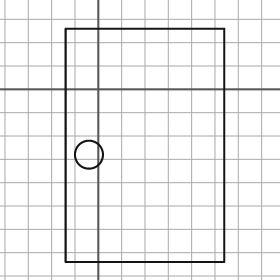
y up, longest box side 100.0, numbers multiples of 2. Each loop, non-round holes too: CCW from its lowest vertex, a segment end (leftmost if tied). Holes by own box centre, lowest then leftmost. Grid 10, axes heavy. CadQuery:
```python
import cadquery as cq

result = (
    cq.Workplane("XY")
    .moveTo(-14.0, -74.0)
    .lineTo(54.0, -74.0)
    .lineTo(54.0, 26.0)
    .lineTo(-14.0, 26.0)
    .close()
    .moveTo(-4.0, -28.0)
    .circle(6.0)
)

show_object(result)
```